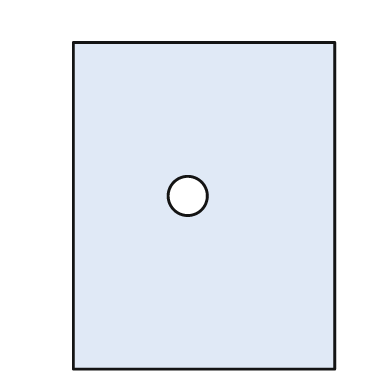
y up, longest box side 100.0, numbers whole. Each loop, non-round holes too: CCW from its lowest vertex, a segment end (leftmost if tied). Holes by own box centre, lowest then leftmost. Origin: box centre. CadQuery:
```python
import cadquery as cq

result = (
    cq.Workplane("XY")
    .moveTo(-40.0, -50.0)
    .lineTo(40.0, -50.0)
    .lineTo(40.0, 50.0)
    .lineTo(-40.0, 50.0)
    .close()
    .moveTo(-5.0, 3.0)
    .circle(6.0)
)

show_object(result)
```